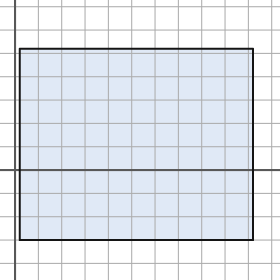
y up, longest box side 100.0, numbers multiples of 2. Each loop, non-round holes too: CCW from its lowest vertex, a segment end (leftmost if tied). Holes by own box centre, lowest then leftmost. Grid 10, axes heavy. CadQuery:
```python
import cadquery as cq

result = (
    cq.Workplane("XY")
    .moveTo(2.0, -30.0)
    .lineTo(102.0, -30.0)
    .lineTo(102.0, 52.0)
    .lineTo(2.0, 52.0)
    .close()
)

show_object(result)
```